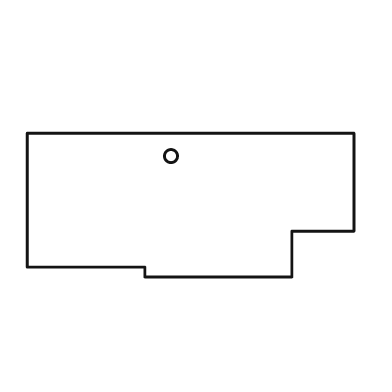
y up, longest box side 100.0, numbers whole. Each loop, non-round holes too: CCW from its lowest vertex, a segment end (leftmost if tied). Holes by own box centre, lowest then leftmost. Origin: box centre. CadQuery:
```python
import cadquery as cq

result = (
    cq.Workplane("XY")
    .moveTo(-14.0, -22.0)
    .lineTo(31.0, -22.0)
    .lineTo(31.0, -8.0)
    .lineTo(50.0, -8.0)
    .lineTo(50.0, 22.0)
    .lineTo(-50.0, 22.0)
    .lineTo(-50.0, -19.0)
    .lineTo(-14.0, -19.0)
    .close()
    .moveTo(-6.0, 15.0)
    .circle(2.0)
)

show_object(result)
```